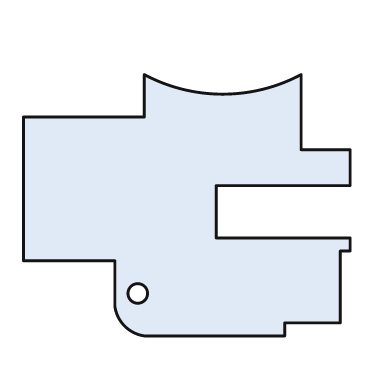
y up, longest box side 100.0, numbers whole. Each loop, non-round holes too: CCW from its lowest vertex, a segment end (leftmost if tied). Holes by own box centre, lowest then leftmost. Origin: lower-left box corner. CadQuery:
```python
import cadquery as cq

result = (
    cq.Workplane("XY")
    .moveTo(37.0, 0.0)
    .lineTo(80.0, 0.0)
    .lineTo(80.0, 4.0)
    .lineTo(97.0, 4.0)
    .lineTo(97.0, 26.0)
    .lineTo(100.0, 26.0)
    .lineTo(100.0, 30.0)
    .lineTo(59.0, 30.0)
    .lineTo(59.0, 46.0)
    .lineTo(100.0, 46.0)
    .lineTo(100.0, 57.0)
    .lineTo(85.0, 57.0)
    .lineTo(85.0, 80.0)
    .threePointArc((61.0, 74.0), (37.0, 80.0))
    .lineTo(37.0, 67.0)
    .lineTo(0.0, 67.0)
    .lineTo(0.0, 23.0)
    .lineTo(28.0, 23.0)
    .lineTo(28.0, 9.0)
    .threePointArc((31.0, 3.0), (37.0, 0.0))
    .close()
    .moveTo(35.0, 13.0)
    .circle(3.0)
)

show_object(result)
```